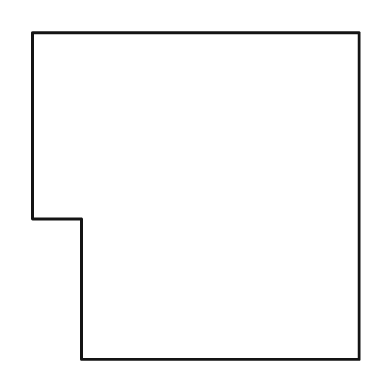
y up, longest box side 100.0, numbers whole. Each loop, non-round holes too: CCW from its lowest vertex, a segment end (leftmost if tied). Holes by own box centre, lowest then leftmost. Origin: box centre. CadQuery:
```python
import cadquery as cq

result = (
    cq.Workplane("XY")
    .moveTo(-35.0, -50.0)
    .lineTo(50.0, -50.0)
    .lineTo(50.0, 50.0)
    .lineTo(-50.0, 50.0)
    .lineTo(-50.0, -7.0)
    .lineTo(-35.0, -7.0)
    .close()
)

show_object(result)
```